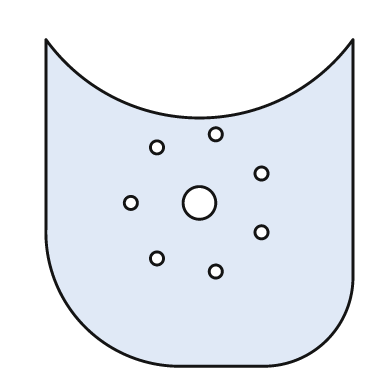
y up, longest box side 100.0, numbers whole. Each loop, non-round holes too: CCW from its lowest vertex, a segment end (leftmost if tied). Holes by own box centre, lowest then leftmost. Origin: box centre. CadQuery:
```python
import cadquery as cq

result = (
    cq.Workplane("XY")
    .moveTo(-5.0, -50.0)
    .lineTo(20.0, -50.0)
    .threePointArc((39.0, -42.0), (47.0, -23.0))
    .lineTo(47.0, 50.0)
    .threePointArc((0.0, 26.0), (-47.0, 50.0))
    .lineTo(-47.0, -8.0)
    .threePointArc((-35.0, -38.0), (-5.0, -50.0))
    .close()
    .moveTo(5.0, -21.0)
    .circle(2.0)
    .moveTo(-13.0, -17.0)
    .circle(2.0)
    .moveTo(19.0, -9.0)
    .circle(2.0)
    .moveTo(-21.0, 0.0)
    .circle(2.0)
    .moveTo(0.0, 0.0)
    .circle(5.0)
    .moveTo(19.0, 9.0)
    .circle(2.0)
    .moveTo(-13.0, 17.0)
    .circle(2.0)
    .moveTo(5.0, 21.0)
    .circle(2.0)
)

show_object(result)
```